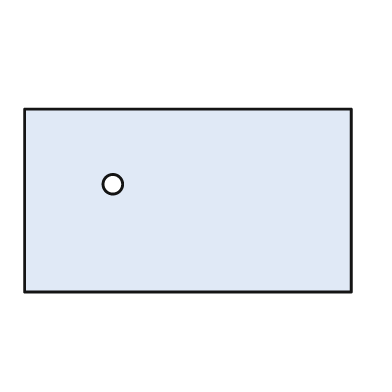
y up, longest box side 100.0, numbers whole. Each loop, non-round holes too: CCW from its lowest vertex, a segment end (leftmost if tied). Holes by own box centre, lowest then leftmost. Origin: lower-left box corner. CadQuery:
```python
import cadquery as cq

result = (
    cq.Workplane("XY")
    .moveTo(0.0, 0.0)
    .lineTo(100.0, 0.0)
    .lineTo(100.0, 56.0)
    .lineTo(0.0, 56.0)
    .close()
    .moveTo(27.0, 33.0)
    .circle(3.0)
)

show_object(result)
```